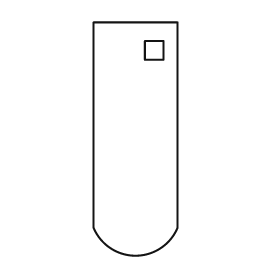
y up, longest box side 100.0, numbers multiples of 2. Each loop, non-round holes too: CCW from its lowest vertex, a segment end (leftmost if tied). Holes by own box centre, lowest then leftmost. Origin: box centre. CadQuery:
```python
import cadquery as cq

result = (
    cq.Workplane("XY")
    .moveTo(-18.0, -38.0)
    .threePointArc((0.0, -50.0), (18.0, -38.0))
    .lineTo(18.0, 50.0)
    .lineTo(-18.0, 50.0)
    .close()
    .moveTo(4.0, 34.0)
    .lineTo(12.0, 34.0)
    .lineTo(12.0, 42.0)
    .lineTo(4.0, 42.0)
    .close()
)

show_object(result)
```